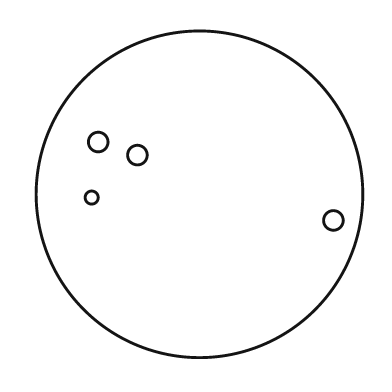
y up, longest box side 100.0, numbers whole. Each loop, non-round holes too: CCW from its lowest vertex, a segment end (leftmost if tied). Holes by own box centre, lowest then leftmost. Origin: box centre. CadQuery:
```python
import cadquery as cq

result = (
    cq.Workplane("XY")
    .moveTo(0.0, 0.0)
    .circle(50.0)
    .moveTo(41.0, -8.0)
    .circle(3.0)
    .moveTo(-33.0, -1.0)
    .circle(2.0)
    .moveTo(-19.0, 12.0)
    .circle(3.0)
    .moveTo(-31.0, 16.0)
    .circle(3.0)
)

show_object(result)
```